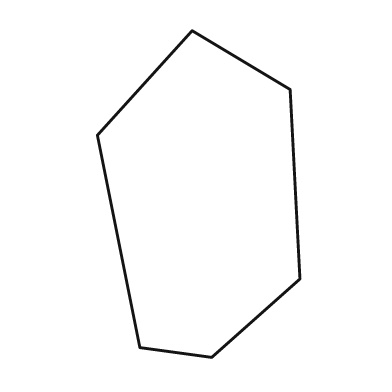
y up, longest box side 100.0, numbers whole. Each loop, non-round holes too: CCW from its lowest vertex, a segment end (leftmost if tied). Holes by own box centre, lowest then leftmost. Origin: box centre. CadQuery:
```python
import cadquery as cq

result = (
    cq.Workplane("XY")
    .moveTo(4.0, -50.0)
    .lineTo(31.0, -26.0)
    .lineTo(28.0, 32.0)
    .lineTo(-2.0, 50.0)
    .lineTo(-31.0, 18.0)
    .lineTo(-18.0, -47.0)
    .close()
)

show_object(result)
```